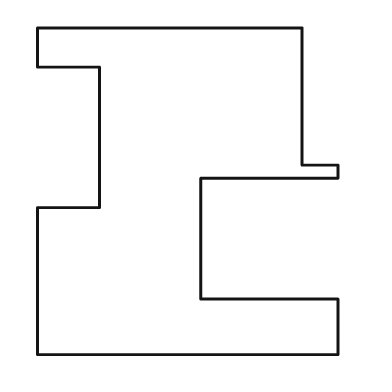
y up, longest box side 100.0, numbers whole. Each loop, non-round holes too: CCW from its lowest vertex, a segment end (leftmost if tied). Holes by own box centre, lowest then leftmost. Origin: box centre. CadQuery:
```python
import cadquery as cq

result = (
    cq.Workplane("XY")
    .moveTo(-46.0, -50.0)
    .lineTo(46.0, -50.0)
    .lineTo(46.0, -33.0)
    .lineTo(4.0, -33.0)
    .lineTo(4.0, 4.0)
    .lineTo(46.0, 4.0)
    .lineTo(46.0, 8.0)
    .lineTo(35.0, 8.0)
    .lineTo(35.0, 50.0)
    .lineTo(-46.0, 50.0)
    .lineTo(-46.0, 38.0)
    .lineTo(-27.0, 38.0)
    .lineTo(-27.0, -5.0)
    .lineTo(-46.0, -5.0)
    .close()
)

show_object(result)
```